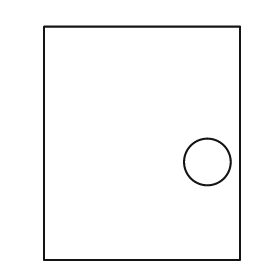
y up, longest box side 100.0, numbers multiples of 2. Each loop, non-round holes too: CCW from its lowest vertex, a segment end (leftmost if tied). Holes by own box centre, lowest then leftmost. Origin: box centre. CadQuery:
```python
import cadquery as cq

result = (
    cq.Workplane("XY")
    .moveTo(-42.0, -50.0)
    .lineTo(42.0, -50.0)
    .lineTo(42.0, 50.0)
    .lineTo(-42.0, 50.0)
    .close()
    .moveTo(28.0, -8.0)
    .circle(10.0)
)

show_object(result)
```